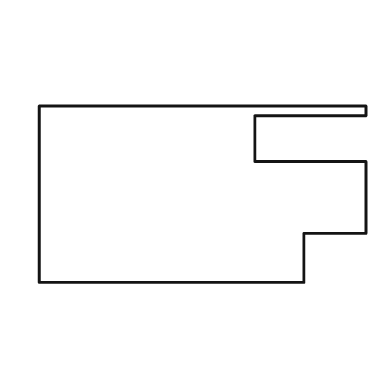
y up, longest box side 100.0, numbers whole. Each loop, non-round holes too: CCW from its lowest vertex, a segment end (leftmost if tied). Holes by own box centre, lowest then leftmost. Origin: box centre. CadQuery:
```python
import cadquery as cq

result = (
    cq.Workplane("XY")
    .moveTo(-50.0, -27.0)
    .lineTo(31.0, -27.0)
    .lineTo(31.0, -12.0)
    .lineTo(50.0, -12.0)
    .lineTo(50.0, 10.0)
    .lineTo(16.0, 10.0)
    .lineTo(16.0, 24.0)
    .lineTo(50.0, 24.0)
    .lineTo(50.0, 27.0)
    .lineTo(-50.0, 27.0)
    .close()
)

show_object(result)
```